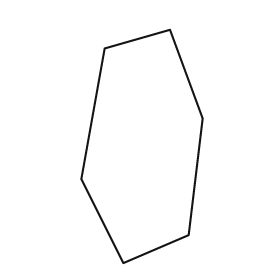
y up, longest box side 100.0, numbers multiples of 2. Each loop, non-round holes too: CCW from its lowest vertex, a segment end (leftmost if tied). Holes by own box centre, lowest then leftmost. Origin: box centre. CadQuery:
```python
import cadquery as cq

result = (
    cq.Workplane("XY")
    .moveTo(-8.0, -50.0)
    .lineTo(20.0, -38.0)
    .lineTo(26.0, 12.0)
    .lineTo(12.0, 50.0)
    .lineTo(-16.0, 42.0)
    .lineTo(-26.0, -14.0)
    .close()
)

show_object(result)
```